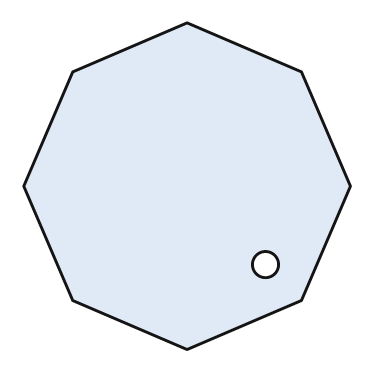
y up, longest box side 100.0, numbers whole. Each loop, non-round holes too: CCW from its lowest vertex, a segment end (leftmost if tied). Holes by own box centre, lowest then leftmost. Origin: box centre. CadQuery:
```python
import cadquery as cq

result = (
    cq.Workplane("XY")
    .moveTo(0.0, -50.0)
    .lineTo(35.0, -35.0)
    .lineTo(50.0, 0.0)
    .lineTo(35.0, 35.0)
    .lineTo(0.0, 50.0)
    .lineTo(-35.0, 35.0)
    .lineTo(-50.0, 0.0)
    .lineTo(-35.0, -35.0)
    .close()
    .moveTo(24.0, -24.0)
    .circle(4.0)
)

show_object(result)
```